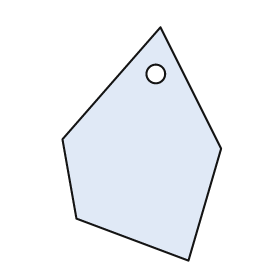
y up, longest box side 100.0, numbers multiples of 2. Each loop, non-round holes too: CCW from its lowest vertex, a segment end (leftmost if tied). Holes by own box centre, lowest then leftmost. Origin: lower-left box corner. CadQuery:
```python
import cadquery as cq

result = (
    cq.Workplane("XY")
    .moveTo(54.0, 0.0)
    .lineTo(68.0, 48.0)
    .lineTo(42.0, 100.0)
    .lineTo(0.0, 52.0)
    .lineTo(6.0, 18.0)
    .close()
    .moveTo(40.0, 80.0)
    .circle(4.0)
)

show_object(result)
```